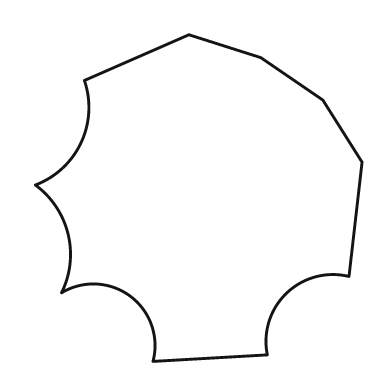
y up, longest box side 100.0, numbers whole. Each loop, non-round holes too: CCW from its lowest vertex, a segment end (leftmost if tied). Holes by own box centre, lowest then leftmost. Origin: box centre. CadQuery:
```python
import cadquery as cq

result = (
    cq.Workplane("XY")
    .moveTo(-14.0, -50.0)
    .lineTo(21.0, -48.0)
    .threePointArc((27.0, -29.0), (46.0, -24.0))
    .lineTo(50.0, 11.0)
    .lineTo(38.0, 30.0)
    .lineTo(19.0, 43.0)
    .lineTo(-3.0, 50.0)
    .lineTo(-35.0, 36.0)
    .threePointArc((-36.0, 17.0), (-50.0, 4.0))
    .threePointArc((-40.0, -11.0), (-42.0, -29.0))
    .threePointArc((-21.0, -30.0), (-14.0, -50.0))
    .close()
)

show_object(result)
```